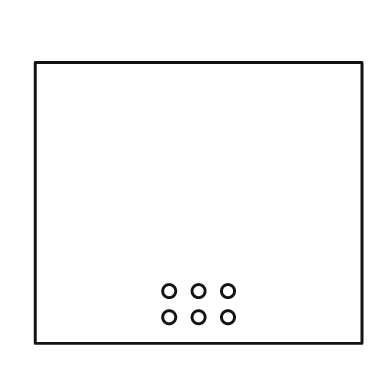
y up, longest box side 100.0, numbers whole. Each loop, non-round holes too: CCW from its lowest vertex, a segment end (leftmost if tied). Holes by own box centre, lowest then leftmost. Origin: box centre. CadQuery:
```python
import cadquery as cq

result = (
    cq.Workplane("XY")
    .moveTo(-50.0, -43.0)
    .lineTo(50.0, -43.0)
    .lineTo(50.0, 43.0)
    .lineTo(-50.0, 43.0)
    .close()
    .moveTo(-9.0, -35.0)
    .circle(2.0)
    .moveTo(0.0, -35.0)
    .circle(2.0)
    .moveTo(9.0, -35.0)
    .circle(2.0)
    .moveTo(-9.0, -27.0)
    .circle(2.0)
    .moveTo(0.0, -27.0)
    .circle(2.0)
    .moveTo(9.0, -27.0)
    .circle(2.0)
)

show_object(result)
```